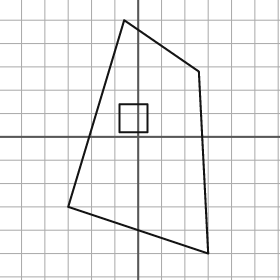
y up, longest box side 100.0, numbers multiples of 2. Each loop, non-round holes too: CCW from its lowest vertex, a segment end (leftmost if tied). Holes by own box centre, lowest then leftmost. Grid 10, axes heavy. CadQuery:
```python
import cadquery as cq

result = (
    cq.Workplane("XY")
    .moveTo(30.0, -50.0)
    .lineTo(26.0, 28.0)
    .lineTo(-6.0, 50.0)
    .lineTo(-30.0, -30.0)
    .close()
    .moveTo(-8.0, 2.0)
    .lineTo(4.0, 2.0)
    .lineTo(4.0, 14.0)
    .lineTo(-8.0, 14.0)
    .close()
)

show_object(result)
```